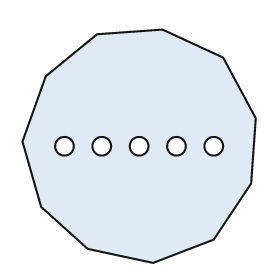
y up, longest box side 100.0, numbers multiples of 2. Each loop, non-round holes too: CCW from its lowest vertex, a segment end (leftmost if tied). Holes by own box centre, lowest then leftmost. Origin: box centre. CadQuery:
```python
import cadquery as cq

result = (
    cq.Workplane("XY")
    .moveTo(6.0, -50.0)
    .lineTo(32.0, -40.0)
    .lineTo(48.0, -16.0)
    .lineTo(50.0, 12.0)
    .lineTo(36.0, 38.0)
    .lineTo(10.0, 50.0)
    .lineTo(-18.0, 48.0)
    .lineTo(-40.0, 30.0)
    .lineTo(-50.0, 2.0)
    .lineTo(-42.0, -26.0)
    .lineTo(-22.0, -44.0)
    .close()
    .moveTo(-32.0, 0.0)
    .circle(4.0)
    .moveTo(-16.0, 0.0)
    .circle(4.0)
    .moveTo(0.0, 0.0)
    .circle(4.0)
    .moveTo(16.0, 0.0)
    .circle(4.0)
    .moveTo(32.0, 0.0)
    .circle(4.0)
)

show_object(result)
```